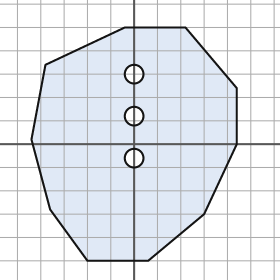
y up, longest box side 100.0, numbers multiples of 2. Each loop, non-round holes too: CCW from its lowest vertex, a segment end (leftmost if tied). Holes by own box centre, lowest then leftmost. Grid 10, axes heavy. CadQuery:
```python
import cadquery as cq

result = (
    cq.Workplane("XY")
    .moveTo(-20.0, -50.0)
    .lineTo(6.0, -50.0)
    .lineTo(30.0, -30.0)
    .lineTo(44.0, 0.0)
    .lineTo(44.0, 24.0)
    .lineTo(22.0, 50.0)
    .lineTo(-4.0, 50.0)
    .lineTo(-38.0, 34.0)
    .lineTo(-44.0, 2.0)
    .lineTo(-36.0, -28.0)
    .close()
    .moveTo(0.0, -6.0)
    .circle(4.0)
    .moveTo(0.0, 12.0)
    .circle(4.0)
    .moveTo(0.0, 30.0)
    .circle(4.0)
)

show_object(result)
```